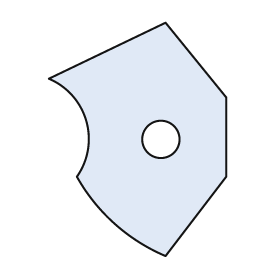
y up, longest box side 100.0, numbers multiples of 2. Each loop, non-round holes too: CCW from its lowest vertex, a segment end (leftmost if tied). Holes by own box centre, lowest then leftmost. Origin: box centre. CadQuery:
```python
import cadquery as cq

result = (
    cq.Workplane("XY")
    .moveTo(12.0, -50.0)
    .lineTo(38.0, -16.0)
    .lineTo(38.0, 18.0)
    .lineTo(12.0, 50.0)
    .lineTo(-38.0, 26.0)
    .threePointArc((-22.0, 8.0), (-26.0, -16.0))
    .threePointArc((-10.0, -36.0), (12.0, -50.0))
    .close()
    .moveTo(10.0, 0.0)
    .circle(8.0)
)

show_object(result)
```